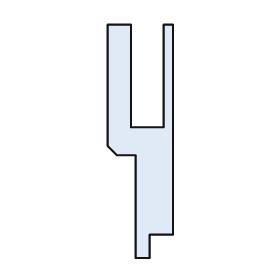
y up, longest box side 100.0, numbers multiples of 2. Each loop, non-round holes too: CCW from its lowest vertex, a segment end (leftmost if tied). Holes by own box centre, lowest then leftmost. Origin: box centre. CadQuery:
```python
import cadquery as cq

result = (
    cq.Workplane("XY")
    .moveTo(-2.0, -50.0)
    .lineTo(4.0, -50.0)
    .lineTo(4.0, -40.0)
    .lineTo(14.0, -40.0)
    .lineTo(14.0, 50.0)
    .lineTo(10.0, 50.0)
    .lineTo(10.0, 6.0)
    .lineTo(-4.0, 6.0)
    .lineTo(-4.0, 50.0)
    .lineTo(-14.0, 50.0)
    .lineTo(-14.0, -2.0)
    .lineTo(-10.0, -6.0)
    .lineTo(-2.0, -6.0)
    .close()
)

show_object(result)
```